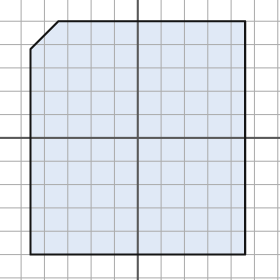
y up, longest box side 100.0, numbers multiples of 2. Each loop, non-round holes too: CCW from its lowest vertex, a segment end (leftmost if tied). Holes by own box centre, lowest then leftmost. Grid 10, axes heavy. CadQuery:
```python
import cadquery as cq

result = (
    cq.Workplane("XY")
    .moveTo(-46.0, -50.0)
    .lineTo(46.0, -50.0)
    .lineTo(46.0, 50.0)
    .lineTo(-34.0, 50.0)
    .lineTo(-46.0, 38.0)
    .close()
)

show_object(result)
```